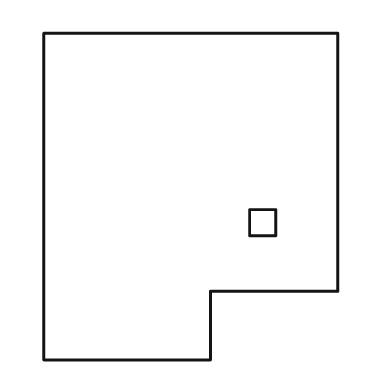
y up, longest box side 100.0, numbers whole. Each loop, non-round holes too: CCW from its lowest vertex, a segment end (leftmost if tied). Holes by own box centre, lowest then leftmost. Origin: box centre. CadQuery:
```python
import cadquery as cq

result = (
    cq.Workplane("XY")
    .moveTo(-45.0, -50.0)
    .lineTo(6.0, -50.0)
    .lineTo(6.0, -29.0)
    .lineTo(45.0, -29.0)
    .lineTo(45.0, 50.0)
    .lineTo(-45.0, 50.0)
    .close()
    .moveTo(18.0, -12.0)
    .lineTo(26.0, -12.0)
    .lineTo(26.0, -4.0)
    .lineTo(18.0, -4.0)
    .close()
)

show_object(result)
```